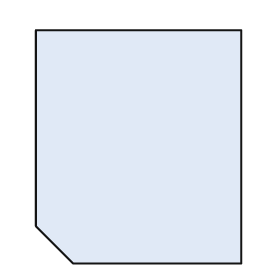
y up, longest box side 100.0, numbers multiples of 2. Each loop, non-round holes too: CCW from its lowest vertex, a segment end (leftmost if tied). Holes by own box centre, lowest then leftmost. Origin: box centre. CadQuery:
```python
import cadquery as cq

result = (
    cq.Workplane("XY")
    .moveTo(-28.0, -50.0)
    .lineTo(44.0, -50.0)
    .lineTo(44.0, 50.0)
    .lineTo(-44.0, 50.0)
    .lineTo(-44.0, -34.0)
    .close()
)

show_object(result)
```